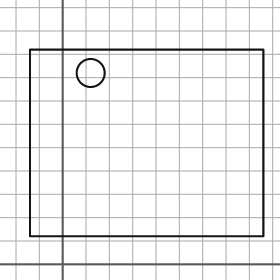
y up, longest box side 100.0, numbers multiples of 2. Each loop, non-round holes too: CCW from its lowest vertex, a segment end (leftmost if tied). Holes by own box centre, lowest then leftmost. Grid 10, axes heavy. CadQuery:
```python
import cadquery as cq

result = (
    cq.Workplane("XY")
    .moveTo(-14.0, 12.0)
    .lineTo(86.0, 12.0)
    .lineTo(86.0, 92.0)
    .lineTo(-14.0, 92.0)
    .close()
    .moveTo(12.0, 82.0)
    .circle(6.0)
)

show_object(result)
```